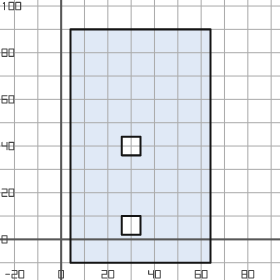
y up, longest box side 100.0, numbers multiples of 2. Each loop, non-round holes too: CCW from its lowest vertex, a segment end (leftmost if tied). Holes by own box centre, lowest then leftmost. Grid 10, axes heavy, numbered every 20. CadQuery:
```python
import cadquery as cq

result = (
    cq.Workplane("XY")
    .moveTo(4.0, -10.0)
    .lineTo(64.0, -10.0)
    .lineTo(64.0, 90.0)
    .lineTo(4.0, 90.0)
    .close()
    .moveTo(26.0, 2.0)
    .lineTo(34.0, 2.0)
    .lineTo(34.0, 10.0)
    .lineTo(26.0, 10.0)
    .close()
    .moveTo(26.0, 36.0)
    .lineTo(34.0, 36.0)
    .lineTo(34.0, 44.0)
    .lineTo(26.0, 44.0)
    .close()
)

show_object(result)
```